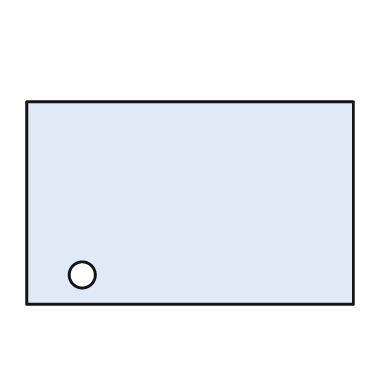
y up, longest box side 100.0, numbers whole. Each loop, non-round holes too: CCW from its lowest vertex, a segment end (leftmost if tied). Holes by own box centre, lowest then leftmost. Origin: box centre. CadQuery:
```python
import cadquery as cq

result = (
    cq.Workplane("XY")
    .moveTo(-50.0, -31.0)
    .lineTo(50.0, -31.0)
    .lineTo(50.0, 31.0)
    .lineTo(-50.0, 31.0)
    .close()
    .moveTo(-33.0, -22.0)
    .circle(4.0)
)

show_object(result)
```